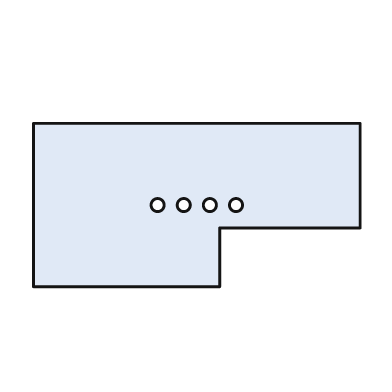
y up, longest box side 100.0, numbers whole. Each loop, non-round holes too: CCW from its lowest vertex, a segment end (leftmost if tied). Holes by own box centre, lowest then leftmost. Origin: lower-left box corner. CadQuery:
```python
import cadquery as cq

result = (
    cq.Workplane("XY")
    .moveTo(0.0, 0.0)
    .lineTo(57.0, 0.0)
    .lineTo(57.0, 18.0)
    .lineTo(100.0, 18.0)
    .lineTo(100.0, 50.0)
    .lineTo(0.0, 50.0)
    .close()
    .moveTo(38.0, 25.0)
    .circle(2.0)
    .moveTo(46.0, 25.0)
    .circle(2.0)
    .moveTo(54.0, 25.0)
    .circle(2.0)
    .moveTo(62.0, 25.0)
    .circle(2.0)
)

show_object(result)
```